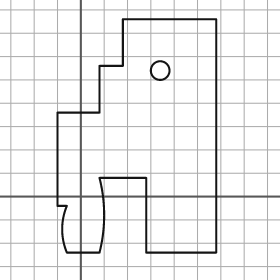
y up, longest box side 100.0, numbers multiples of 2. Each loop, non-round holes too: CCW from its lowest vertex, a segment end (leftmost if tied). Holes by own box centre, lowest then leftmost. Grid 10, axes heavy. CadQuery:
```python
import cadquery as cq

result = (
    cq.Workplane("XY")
    .moveTo(-6.0, -24.0)
    .lineTo(8.0, -24.0)
    .threePointArc((10.0, -8.0), (8.0, 8.0))
    .lineTo(28.0, 8.0)
    .lineTo(28.0, -24.0)
    .lineTo(58.0, -24.0)
    .lineTo(58.0, 76.0)
    .lineTo(18.0, 76.0)
    .lineTo(18.0, 56.0)
    .lineTo(8.0, 56.0)
    .lineTo(8.0, 36.0)
    .lineTo(-10.0, 36.0)
    .lineTo(-10.0, -4.0)
    .lineTo(-6.0, -4.0)
    .threePointArc((-8.0, -14.0), (-6.0, -24.0))
    .close()
    .moveTo(34.0, 54.0)
    .circle(4.0)
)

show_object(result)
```